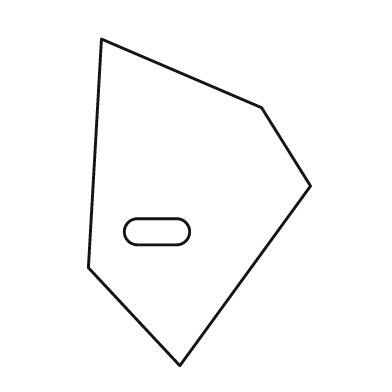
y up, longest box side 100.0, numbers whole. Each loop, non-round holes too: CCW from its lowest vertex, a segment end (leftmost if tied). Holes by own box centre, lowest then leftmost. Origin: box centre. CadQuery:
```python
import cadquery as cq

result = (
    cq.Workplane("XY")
    .moveTo(-6.0, -50.0)
    .lineTo(34.0, 5.0)
    .lineTo(19.0, 29.0)
    .lineTo(-30.0, 50.0)
    .lineTo(-34.0, -20.0)
    .close()
    .moveTo(-19.0, -13.0)
    .lineTo(-7.0, -13.0)
    .threePointArc((-3.0, -9.0), (-7.0, -5.0))
    .lineTo(-19.0, -5.0)
    .threePointArc((-23.0, -9.0), (-19.0, -13.0))
    .close()
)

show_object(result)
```